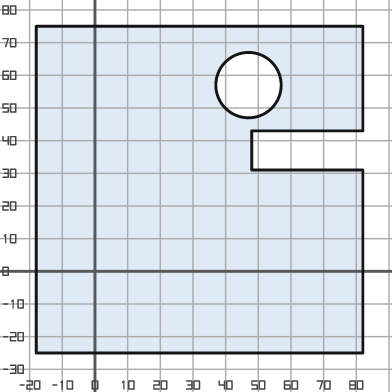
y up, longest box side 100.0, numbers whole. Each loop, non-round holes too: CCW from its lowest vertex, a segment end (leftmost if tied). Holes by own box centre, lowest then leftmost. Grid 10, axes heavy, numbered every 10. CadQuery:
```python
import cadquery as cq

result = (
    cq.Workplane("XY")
    .moveTo(-18.0, -25.0)
    .lineTo(82.0, -25.0)
    .lineTo(82.0, 31.0)
    .lineTo(48.0, 31.0)
    .lineTo(48.0, 43.0)
    .lineTo(82.0, 43.0)
    .lineTo(82.0, 75.0)
    .lineTo(-18.0, 75.0)
    .close()
    .moveTo(47.0, 57.0)
    .circle(10.0)
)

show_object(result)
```